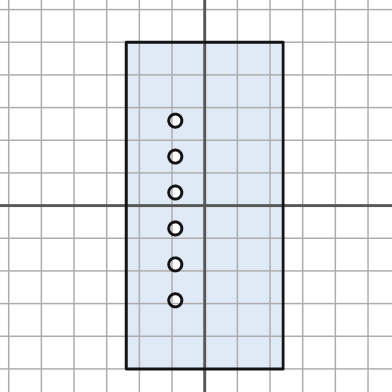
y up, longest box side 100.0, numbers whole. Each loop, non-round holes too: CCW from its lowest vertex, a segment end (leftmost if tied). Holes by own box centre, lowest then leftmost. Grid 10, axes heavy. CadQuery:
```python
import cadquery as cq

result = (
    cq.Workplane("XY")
    .moveTo(-24.0, -50.0)
    .lineTo(24.0, -50.0)
    .lineTo(24.0, 50.0)
    .lineTo(-24.0, 50.0)
    .close()
    .moveTo(-9.0, -29.0)
    .circle(2.0)
    .moveTo(-9.0, -18.0)
    .circle(2.0)
    .moveTo(-9.0, -7.0)
    .circle(2.0)
    .moveTo(-9.0, 4.0)
    .circle(2.0)
    .moveTo(-9.0, 15.0)
    .circle(2.0)
    .moveTo(-9.0, 26.0)
    .circle(2.0)
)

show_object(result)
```